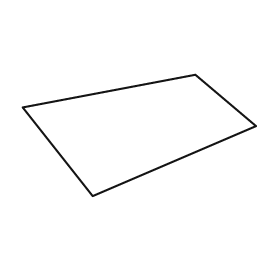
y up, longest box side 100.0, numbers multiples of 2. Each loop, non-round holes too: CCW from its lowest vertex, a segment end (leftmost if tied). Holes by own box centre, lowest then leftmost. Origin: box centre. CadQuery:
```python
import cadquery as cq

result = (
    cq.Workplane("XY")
    .moveTo(-20.0, -26.0)
    .lineTo(50.0, 4.0)
    .lineTo(24.0, 26.0)
    .lineTo(-50.0, 12.0)
    .close()
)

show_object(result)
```